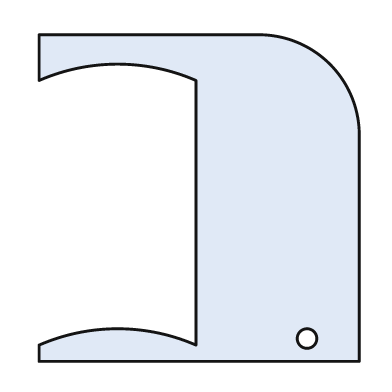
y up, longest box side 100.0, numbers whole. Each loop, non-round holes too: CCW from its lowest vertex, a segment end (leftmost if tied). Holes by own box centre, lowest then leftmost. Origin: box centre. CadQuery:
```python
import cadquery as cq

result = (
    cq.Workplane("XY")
    .moveTo(-49.0, -50.0)
    .lineTo(49.0, -50.0)
    .lineTo(49.0, 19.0)
    .threePointArc((40.0, 41.0), (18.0, 50.0))
    .lineTo(-49.0, 50.0)
    .lineTo(-49.0, 36.0)
    .threePointArc((-25.0, 41.0), (-1.0, 36.0))
    .lineTo(-1.0, -45.0)
    .threePointArc((-25.0, -40.0), (-49.0, -45.0))
    .close()
    .moveTo(33.0, -43.0)
    .circle(3.0)
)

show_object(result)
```